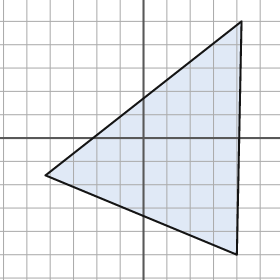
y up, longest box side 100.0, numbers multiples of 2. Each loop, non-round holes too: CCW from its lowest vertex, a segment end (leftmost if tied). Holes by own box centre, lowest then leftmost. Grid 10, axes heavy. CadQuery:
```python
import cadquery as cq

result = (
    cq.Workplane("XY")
    .moveTo(40.0, -50.0)
    .lineTo(42.0, 50.0)
    .lineTo(-42.0, -16.0)
    .close()
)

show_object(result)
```